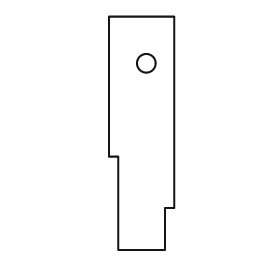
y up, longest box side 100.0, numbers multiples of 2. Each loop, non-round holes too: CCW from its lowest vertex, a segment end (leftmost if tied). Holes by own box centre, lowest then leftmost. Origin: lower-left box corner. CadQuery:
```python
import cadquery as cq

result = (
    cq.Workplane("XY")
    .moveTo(4.0, 0.0)
    .lineTo(24.0, 0.0)
    .lineTo(24.0, 18.0)
    .lineTo(28.0, 18.0)
    .lineTo(28.0, 100.0)
    .lineTo(0.0, 100.0)
    .lineTo(0.0, 40.0)
    .lineTo(4.0, 40.0)
    .close()
    .moveTo(16.0, 80.0)
    .circle(4.0)
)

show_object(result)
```